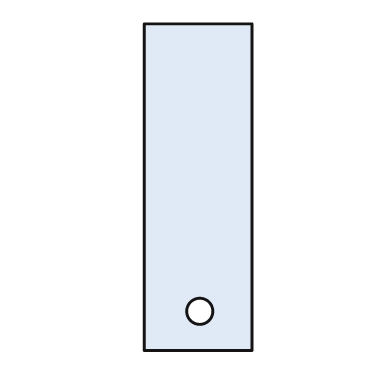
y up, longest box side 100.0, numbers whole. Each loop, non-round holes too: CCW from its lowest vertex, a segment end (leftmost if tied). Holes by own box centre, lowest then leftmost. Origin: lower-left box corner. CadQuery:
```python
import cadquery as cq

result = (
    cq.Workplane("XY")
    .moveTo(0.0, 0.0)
    .lineTo(33.0, 0.0)
    .lineTo(33.0, 100.0)
    .lineTo(0.0, 100.0)
    .close()
    .moveTo(17.0, 12.0)
    .circle(4.0)
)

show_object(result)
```